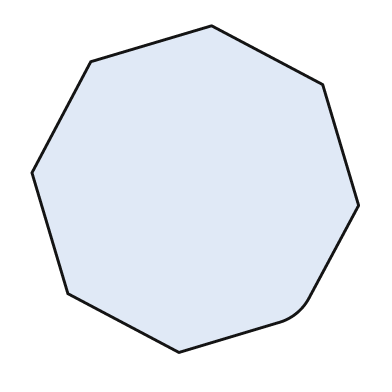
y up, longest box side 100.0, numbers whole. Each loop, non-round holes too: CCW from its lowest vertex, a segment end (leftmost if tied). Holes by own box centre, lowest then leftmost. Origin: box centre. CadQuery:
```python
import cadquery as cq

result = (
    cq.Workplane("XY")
    .moveTo(-5.0, -50.0)
    .lineTo(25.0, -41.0)
    .threePointArc((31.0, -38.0), (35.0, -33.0))
    .lineTo(50.0, -5.0)
    .lineTo(39.0, 32.0)
    .lineTo(5.0, 50.0)
    .lineTo(-32.0, 39.0)
    .lineTo(-50.0, 5.0)
    .lineTo(-39.0, -32.0)
    .close()
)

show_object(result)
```